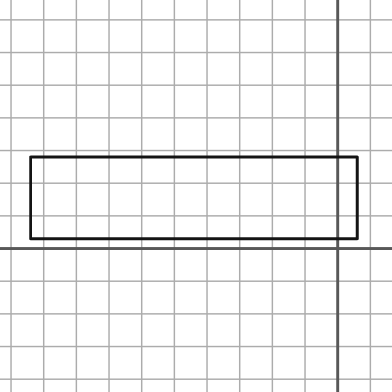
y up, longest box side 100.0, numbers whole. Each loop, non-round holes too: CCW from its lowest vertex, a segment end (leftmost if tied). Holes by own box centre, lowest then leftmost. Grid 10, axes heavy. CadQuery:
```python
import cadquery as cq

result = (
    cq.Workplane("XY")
    .moveTo(-94.0, 3.0)
    .lineTo(6.0, 3.0)
    .lineTo(6.0, 28.0)
    .lineTo(-94.0, 28.0)
    .close()
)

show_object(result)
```